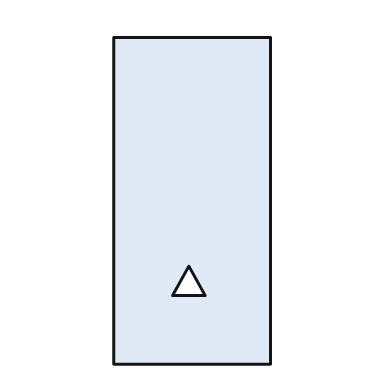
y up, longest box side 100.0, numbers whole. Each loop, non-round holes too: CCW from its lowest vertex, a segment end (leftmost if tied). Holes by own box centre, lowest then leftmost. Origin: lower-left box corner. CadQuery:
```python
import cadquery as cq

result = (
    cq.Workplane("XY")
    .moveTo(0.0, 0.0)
    .lineTo(48.0, 0.0)
    .lineTo(48.0, 100.0)
    .lineTo(0.0, 100.0)
    .close()
    .moveTo(18.0, 21.0)
    .lineTo(28.0, 21.0)
    .lineTo(23.0, 30.0)
    .close()
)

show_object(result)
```